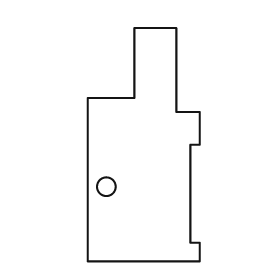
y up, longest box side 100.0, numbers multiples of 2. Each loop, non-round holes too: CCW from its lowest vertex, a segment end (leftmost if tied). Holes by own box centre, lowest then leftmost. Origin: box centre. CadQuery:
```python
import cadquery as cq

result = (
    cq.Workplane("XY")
    .moveTo(-24.0, -50.0)
    .lineTo(24.0, -50.0)
    .lineTo(24.0, -42.0)
    .lineTo(20.0, -42.0)
    .lineTo(20.0, 0.0)
    .lineTo(24.0, 0.0)
    .lineTo(24.0, 14.0)
    .lineTo(14.0, 14.0)
    .lineTo(14.0, 50.0)
    .lineTo(-4.0, 50.0)
    .lineTo(-4.0, 20.0)
    .lineTo(-24.0, 20.0)
    .close()
    .moveTo(-16.0, -18.0)
    .circle(4.0)
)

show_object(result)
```